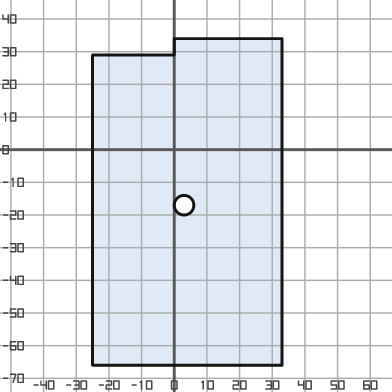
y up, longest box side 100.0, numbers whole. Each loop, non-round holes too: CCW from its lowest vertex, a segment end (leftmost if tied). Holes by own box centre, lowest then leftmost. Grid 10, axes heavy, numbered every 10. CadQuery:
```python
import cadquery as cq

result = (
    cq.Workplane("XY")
    .moveTo(-25.0, -66.0)
    .lineTo(33.0, -66.0)
    .lineTo(33.0, 34.0)
    .lineTo(0.0, 34.0)
    .lineTo(0.0, 29.0)
    .lineTo(-25.0, 29.0)
    .close()
    .moveTo(3.0, -17.0)
    .circle(3.0)
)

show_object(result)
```